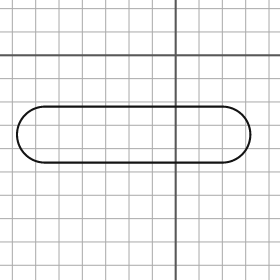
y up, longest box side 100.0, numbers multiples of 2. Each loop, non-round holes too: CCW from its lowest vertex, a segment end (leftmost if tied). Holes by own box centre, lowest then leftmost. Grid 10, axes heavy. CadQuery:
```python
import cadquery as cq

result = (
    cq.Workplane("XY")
    .moveTo(-56.0, -46.0)
    .lineTo(20.0, -46.0)
    .threePointArc((32.0, -34.0), (20.0, -22.0))
    .lineTo(-56.0, -22.0)
    .threePointArc((-68.0, -34.0), (-56.0, -46.0))
    .close()
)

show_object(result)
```